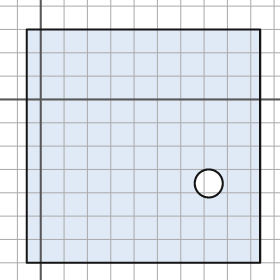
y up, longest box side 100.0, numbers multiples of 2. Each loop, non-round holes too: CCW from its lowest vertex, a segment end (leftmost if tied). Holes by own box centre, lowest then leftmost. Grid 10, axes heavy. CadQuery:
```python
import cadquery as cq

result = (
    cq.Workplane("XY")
    .moveTo(-6.0, -70.0)
    .lineTo(94.0, -70.0)
    .lineTo(94.0, 30.0)
    .lineTo(-6.0, 30.0)
    .close()
    .moveTo(72.0, -36.0)
    .circle(6.0)
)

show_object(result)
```